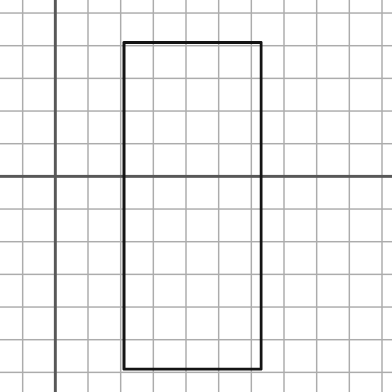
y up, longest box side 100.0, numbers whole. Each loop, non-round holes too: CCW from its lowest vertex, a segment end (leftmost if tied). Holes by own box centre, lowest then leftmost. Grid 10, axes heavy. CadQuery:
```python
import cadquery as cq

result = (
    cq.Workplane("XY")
    .moveTo(21.0, -59.0)
    .lineTo(63.0, -59.0)
    .lineTo(63.0, 41.0)
    .lineTo(21.0, 41.0)
    .close()
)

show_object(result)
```